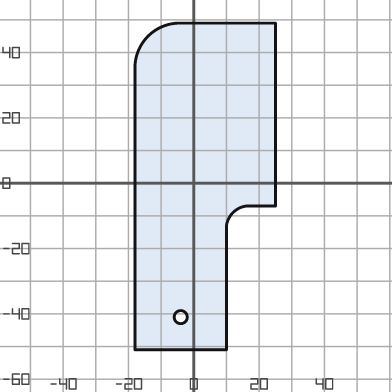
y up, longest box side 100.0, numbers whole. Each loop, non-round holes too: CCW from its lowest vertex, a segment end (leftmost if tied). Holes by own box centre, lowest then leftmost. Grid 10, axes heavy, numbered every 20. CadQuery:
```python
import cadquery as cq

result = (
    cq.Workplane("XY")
    .moveTo(-18.0, -51.0)
    .lineTo(10.0, -51.0)
    .lineTo(10.0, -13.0)
    .threePointArc((12.0, -9.0), (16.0, -7.0))
    .lineTo(25.0, -7.0)
    .lineTo(25.0, 49.0)
    .lineTo(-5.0, 49.0)
    .threePointArc((-14.0, 45.0), (-18.0, 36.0))
    .close()
    .moveTo(-4.0, -41.0)
    .circle(2.0)
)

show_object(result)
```